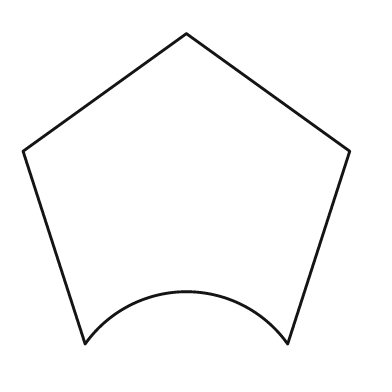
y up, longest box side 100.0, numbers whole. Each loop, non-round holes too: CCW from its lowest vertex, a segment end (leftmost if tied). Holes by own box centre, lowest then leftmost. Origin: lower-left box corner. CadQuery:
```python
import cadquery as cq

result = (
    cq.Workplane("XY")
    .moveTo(19.0, 0.0)
    .threePointArc((50.0, 16.0), (81.0, 0.0))
    .lineTo(100.0, 59.0)
    .lineTo(50.0, 95.0)
    .lineTo(0.0, 59.0)
    .close()
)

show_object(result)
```